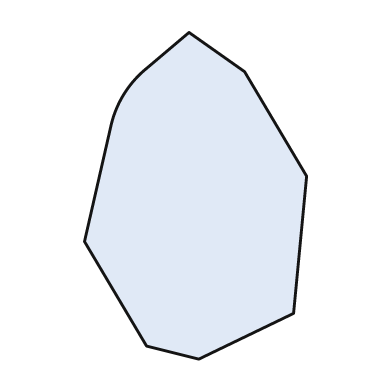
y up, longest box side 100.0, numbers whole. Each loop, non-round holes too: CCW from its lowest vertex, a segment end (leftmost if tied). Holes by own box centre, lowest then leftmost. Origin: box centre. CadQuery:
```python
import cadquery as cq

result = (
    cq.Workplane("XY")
    .moveTo(1.0, -50.0)
    .lineTo(30.0, -36.0)
    .lineTo(34.0, 6.0)
    .lineTo(15.0, 38.0)
    .lineTo(-2.0, 50.0)
    .lineTo(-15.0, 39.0)
    .threePointArc((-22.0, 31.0), (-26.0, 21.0))
    .lineTo(-34.0, -14.0)
    .lineTo(-15.0, -46.0)
    .close()
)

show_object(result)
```